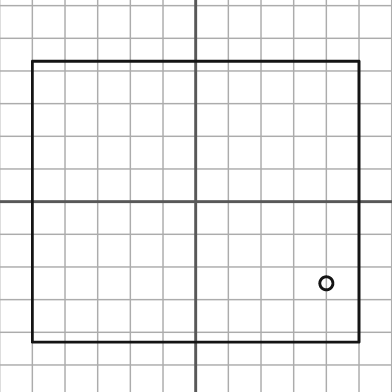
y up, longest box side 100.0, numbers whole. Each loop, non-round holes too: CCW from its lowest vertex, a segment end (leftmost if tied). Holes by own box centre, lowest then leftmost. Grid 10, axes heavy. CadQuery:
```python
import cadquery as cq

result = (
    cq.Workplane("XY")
    .moveTo(-50.0, -43.0)
    .lineTo(50.0, -43.0)
    .lineTo(50.0, 43.0)
    .lineTo(-50.0, 43.0)
    .close()
    .moveTo(40.0, -25.0)
    .circle(2.0)
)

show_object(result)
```